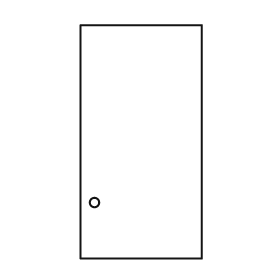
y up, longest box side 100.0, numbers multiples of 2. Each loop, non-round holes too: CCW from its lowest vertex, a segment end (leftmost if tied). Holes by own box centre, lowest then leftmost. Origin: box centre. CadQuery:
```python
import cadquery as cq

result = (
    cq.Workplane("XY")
    .moveTo(-26.0, -50.0)
    .lineTo(26.0, -50.0)
    .lineTo(26.0, 50.0)
    .lineTo(-26.0, 50.0)
    .close()
    .moveTo(-20.0, -26.0)
    .circle(2.0)
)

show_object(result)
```